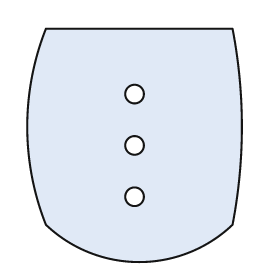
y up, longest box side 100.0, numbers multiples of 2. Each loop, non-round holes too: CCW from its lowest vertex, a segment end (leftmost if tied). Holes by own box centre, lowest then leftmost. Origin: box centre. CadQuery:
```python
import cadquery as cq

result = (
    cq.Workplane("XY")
    .moveTo(-38.0, -34.0)
    .threePointArc((2.0, -50.0), (42.0, -34.0))
    .threePointArc((46.0, 8.0), (42.0, 50.0))
    .lineTo(-38.0, 50.0)
    .threePointArc((-46.0, 8.0), (-38.0, -34.0))
    .close()
    .moveTo(0.0, -22.0)
    .circle(4.0)
    .moveTo(0.0, 0.0)
    .circle(4.0)
    .moveTo(0.0, 22.0)
    .circle(4.0)
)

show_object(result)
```